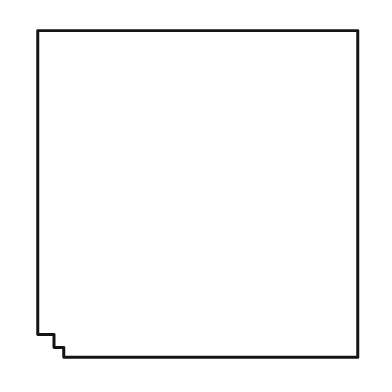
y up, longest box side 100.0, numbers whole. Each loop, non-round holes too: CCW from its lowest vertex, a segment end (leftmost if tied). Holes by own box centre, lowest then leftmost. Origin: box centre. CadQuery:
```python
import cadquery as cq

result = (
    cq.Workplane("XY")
    .moveTo(-41.0, -50.0)
    .lineTo(49.0, -50.0)
    .lineTo(49.0, 50.0)
    .lineTo(-49.0, 50.0)
    .lineTo(-49.0, -43.0)
    .lineTo(-44.0, -43.0)
    .lineTo(-44.0, -47.0)
    .lineTo(-41.0, -47.0)
    .close()
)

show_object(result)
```